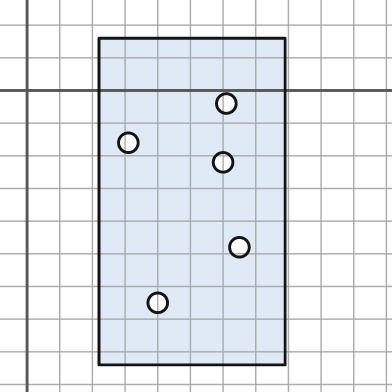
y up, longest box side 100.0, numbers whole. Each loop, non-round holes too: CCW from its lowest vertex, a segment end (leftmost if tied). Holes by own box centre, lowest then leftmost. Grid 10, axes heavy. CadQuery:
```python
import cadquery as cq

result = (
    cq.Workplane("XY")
    .moveTo(22.0, -84.0)
    .lineTo(79.0, -84.0)
    .lineTo(79.0, 16.0)
    .lineTo(22.0, 16.0)
    .close()
    .moveTo(40.0, -65.0)
    .circle(3.0)
    .moveTo(65.0, -48.0)
    .circle(3.0)
    .moveTo(60.0, -22.0)
    .circle(3.0)
    .moveTo(31.0, -16.0)
    .circle(3.0)
    .moveTo(61.0, -4.0)
    .circle(3.0)
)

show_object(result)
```